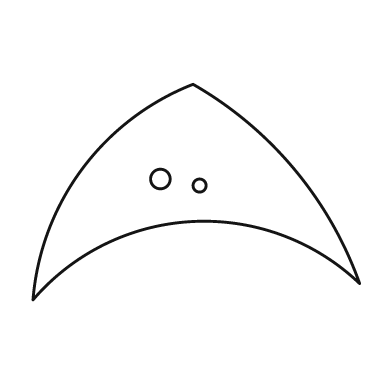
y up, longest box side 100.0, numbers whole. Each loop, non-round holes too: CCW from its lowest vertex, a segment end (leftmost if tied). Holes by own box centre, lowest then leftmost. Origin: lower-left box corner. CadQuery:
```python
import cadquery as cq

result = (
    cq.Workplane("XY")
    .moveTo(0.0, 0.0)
    .threePointArc((49.0, 24.0), (100.0, 5.0))
    .threePointArc((80.0, 40.0), (49.0, 66.0))
    .threePointArc((15.0, 40.0), (0.0, 0.0))
    .close()
    .moveTo(51.0, 35.0)
    .circle(2.0)
    .moveTo(39.0, 37.0)
    .circle(3.0)
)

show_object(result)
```